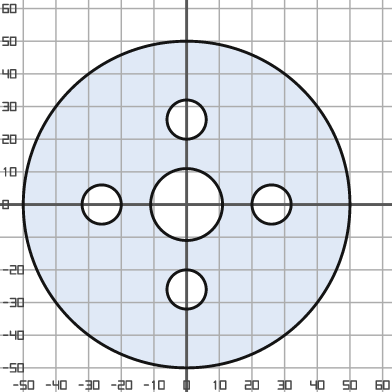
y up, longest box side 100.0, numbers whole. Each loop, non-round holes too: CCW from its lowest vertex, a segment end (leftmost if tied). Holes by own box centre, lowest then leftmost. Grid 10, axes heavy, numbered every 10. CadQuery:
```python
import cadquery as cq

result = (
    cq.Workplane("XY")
    .moveTo(0.0, 0.0)
    .circle(50.0)
    .moveTo(0.0, -26.0)
    .circle(6.0)
    .moveTo(-26.0, 0.0)
    .circle(6.0)
    .moveTo(0.0, 0.0)
    .circle(11.0)
    .moveTo(26.0, 0.0)
    .circle(6.0)
    .moveTo(0.0, 26.0)
    .circle(6.0)
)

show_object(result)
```